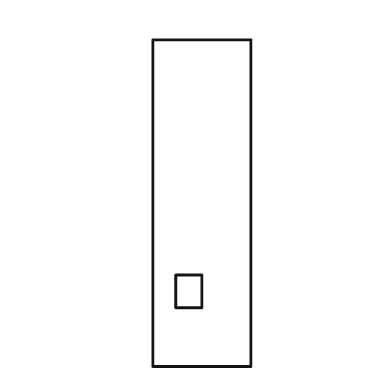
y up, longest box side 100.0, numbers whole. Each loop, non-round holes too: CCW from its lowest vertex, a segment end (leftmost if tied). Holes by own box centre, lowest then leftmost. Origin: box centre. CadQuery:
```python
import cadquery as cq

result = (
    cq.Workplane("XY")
    .moveTo(-15.0, -50.0)
    .lineTo(15.0, -50.0)
    .lineTo(15.0, 50.0)
    .lineTo(-15.0, 50.0)
    .close()
    .moveTo(-8.0, -32.0)
    .lineTo(0.0, -32.0)
    .lineTo(0.0, -22.0)
    .lineTo(-8.0, -22.0)
    .close()
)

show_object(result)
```